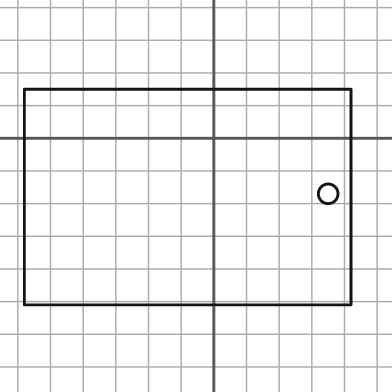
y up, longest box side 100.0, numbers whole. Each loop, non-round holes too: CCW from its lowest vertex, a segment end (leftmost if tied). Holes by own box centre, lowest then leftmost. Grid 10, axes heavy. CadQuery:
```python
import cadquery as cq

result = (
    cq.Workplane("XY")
    .moveTo(-58.0, -51.0)
    .lineTo(42.0, -51.0)
    .lineTo(42.0, 15.0)
    .lineTo(-58.0, 15.0)
    .close()
    .moveTo(35.0, -17.0)
    .circle(3.0)
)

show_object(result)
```